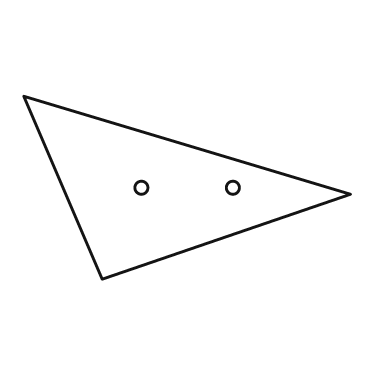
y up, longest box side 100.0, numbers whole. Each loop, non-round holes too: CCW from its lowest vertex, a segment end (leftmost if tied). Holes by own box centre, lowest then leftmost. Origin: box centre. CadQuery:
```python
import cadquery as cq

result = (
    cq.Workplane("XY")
    .moveTo(-26.0, -28.0)
    .lineTo(50.0, -2.0)
    .lineTo(-50.0, 28.0)
    .close()
    .moveTo(-14.0, 0.0)
    .circle(2.0)
    .moveTo(14.0, 0.0)
    .circle(2.0)
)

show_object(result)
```